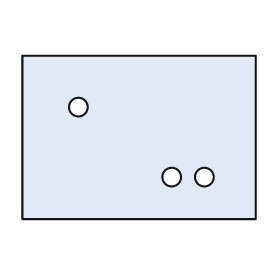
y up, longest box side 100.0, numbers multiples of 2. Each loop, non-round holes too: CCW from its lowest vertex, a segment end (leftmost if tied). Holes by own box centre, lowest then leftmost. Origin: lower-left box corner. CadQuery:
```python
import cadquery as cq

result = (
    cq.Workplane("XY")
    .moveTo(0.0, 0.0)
    .lineTo(100.0, 0.0)
    .lineTo(100.0, 70.0)
    .lineTo(0.0, 70.0)
    .close()
    .moveTo(64.0, 18.0)
    .circle(4.0)
    .moveTo(78.0, 18.0)
    .circle(4.0)
    .moveTo(24.0, 48.0)
    .circle(4.0)
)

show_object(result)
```